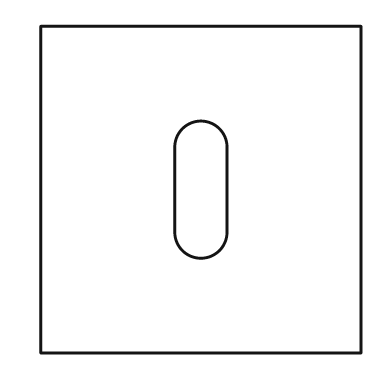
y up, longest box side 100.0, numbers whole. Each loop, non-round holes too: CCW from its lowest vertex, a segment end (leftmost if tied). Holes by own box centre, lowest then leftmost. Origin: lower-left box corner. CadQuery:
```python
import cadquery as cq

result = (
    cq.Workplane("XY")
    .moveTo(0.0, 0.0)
    .lineTo(98.0, 0.0)
    .lineTo(98.0, 100.0)
    .lineTo(0.0, 100.0)
    .close()
    .moveTo(41.0, 37.0)
    .threePointArc((49.0, 29.0), (57.0, 37.0))
    .lineTo(57.0, 63.0)
    .threePointArc((49.0, 71.0), (41.0, 63.0))
    .close()
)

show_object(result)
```